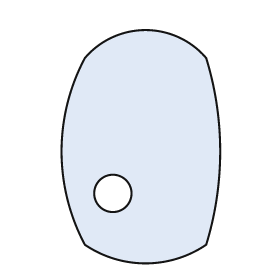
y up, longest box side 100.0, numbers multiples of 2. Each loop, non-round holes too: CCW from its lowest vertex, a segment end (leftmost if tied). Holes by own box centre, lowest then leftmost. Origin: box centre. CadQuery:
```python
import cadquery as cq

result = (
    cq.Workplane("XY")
    .moveTo(-24.0, -42.0)
    .threePointArc((2.0, -50.0), (28.0, -42.0))
    .threePointArc((34.0, -2.0), (28.0, 38.0))
    .threePointArc((2.0, 50.0), (-24.0, 38.0))
    .threePointArc((-34.0, -2.0), (-24.0, -42.0))
    .close()
    .moveTo(-12.0, -20.0)
    .circle(8.0)
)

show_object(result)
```